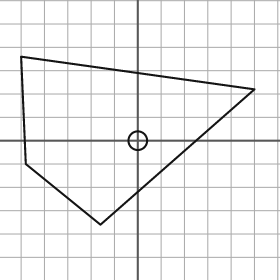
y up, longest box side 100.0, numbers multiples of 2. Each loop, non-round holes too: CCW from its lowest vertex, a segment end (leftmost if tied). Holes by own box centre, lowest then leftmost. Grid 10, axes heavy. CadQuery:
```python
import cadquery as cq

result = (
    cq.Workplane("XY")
    .moveTo(-16.0, -36.0)
    .lineTo(50.0, 22.0)
    .lineTo(-50.0, 36.0)
    .lineTo(-48.0, -10.0)
    .close()
    .moveTo(0.0, 0.0)
    .circle(4.0)
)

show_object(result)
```